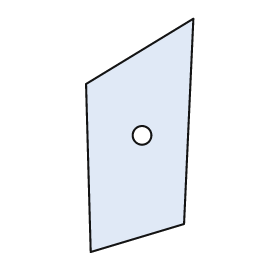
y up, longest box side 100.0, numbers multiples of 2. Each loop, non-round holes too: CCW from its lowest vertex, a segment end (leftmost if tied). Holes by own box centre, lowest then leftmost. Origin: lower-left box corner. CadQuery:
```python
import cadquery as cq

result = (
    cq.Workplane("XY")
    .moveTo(2.0, 0.0)
    .lineTo(42.0, 12.0)
    .lineTo(46.0, 100.0)
    .lineTo(0.0, 72.0)
    .close()
    .moveTo(24.0, 50.0)
    .circle(4.0)
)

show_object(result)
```